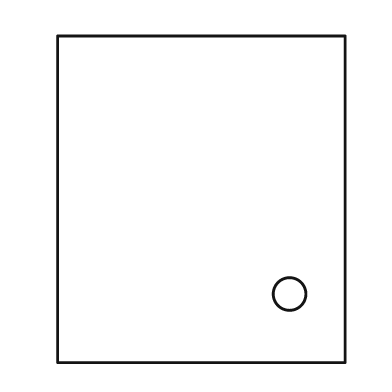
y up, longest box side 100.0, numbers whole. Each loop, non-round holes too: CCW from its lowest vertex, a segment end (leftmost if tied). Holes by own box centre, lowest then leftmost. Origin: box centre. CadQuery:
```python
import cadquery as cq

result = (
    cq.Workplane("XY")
    .moveTo(-44.0, -50.0)
    .lineTo(44.0, -50.0)
    .lineTo(44.0, 50.0)
    .lineTo(-44.0, 50.0)
    .close()
    .moveTo(27.0, -29.0)
    .circle(5.0)
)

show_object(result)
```